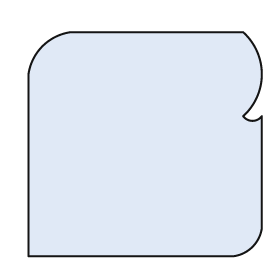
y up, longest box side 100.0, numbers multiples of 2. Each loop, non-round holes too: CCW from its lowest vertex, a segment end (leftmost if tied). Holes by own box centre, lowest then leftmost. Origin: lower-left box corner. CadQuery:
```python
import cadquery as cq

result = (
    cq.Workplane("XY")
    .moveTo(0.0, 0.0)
    .lineTo(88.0, 0.0)
    .threePointArc((96.0, 4.0), (100.0, 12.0))
    .lineTo(100.0, 60.0)
    .threePointArc((96.0, 58.0), (92.0, 60.0))
    .threePointArc((100.0, 78.0), (92.0, 96.0))
    .lineTo(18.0, 96.0)
    .threePointArc((6.0, 90.0), (0.0, 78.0))
    .close()
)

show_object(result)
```